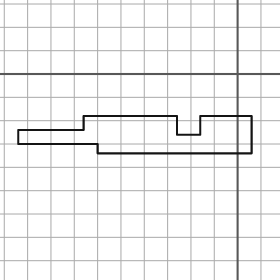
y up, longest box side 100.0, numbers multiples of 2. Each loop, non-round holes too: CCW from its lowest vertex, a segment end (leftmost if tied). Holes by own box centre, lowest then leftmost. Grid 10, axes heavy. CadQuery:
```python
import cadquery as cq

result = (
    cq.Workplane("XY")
    .moveTo(-60.0, -34.0)
    .lineTo(6.0, -34.0)
    .lineTo(6.0, -18.0)
    .lineTo(-16.0, -18.0)
    .lineTo(-16.0, -26.0)
    .lineTo(-26.0, -26.0)
    .lineTo(-26.0, -18.0)
    .lineTo(-66.0, -18.0)
    .lineTo(-66.0, -24.0)
    .lineTo(-94.0, -24.0)
    .lineTo(-94.0, -30.0)
    .lineTo(-60.0, -30.0)
    .close()
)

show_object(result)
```